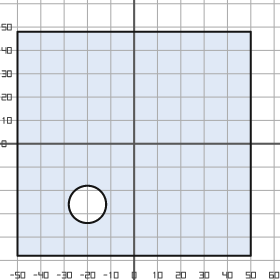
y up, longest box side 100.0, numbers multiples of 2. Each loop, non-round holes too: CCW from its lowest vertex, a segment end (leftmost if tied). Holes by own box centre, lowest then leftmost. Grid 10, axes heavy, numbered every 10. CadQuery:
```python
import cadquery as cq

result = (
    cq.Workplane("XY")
    .moveTo(-50.0, -48.0)
    .lineTo(50.0, -48.0)
    .lineTo(50.0, 48.0)
    .lineTo(-50.0, 48.0)
    .close()
    .moveTo(-20.0, -26.0)
    .circle(8.0)
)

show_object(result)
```